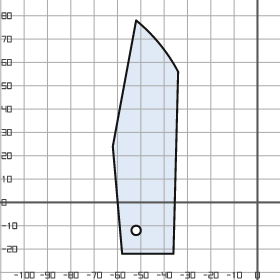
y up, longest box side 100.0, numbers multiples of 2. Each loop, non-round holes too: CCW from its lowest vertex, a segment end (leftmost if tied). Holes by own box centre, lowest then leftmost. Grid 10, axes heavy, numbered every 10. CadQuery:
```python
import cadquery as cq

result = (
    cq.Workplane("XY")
    .moveTo(-58.0, -22.0)
    .lineTo(-36.0, -22.0)
    .lineTo(-34.0, 56.0)
    .threePointArc((-42.0, 68.0), (-52.0, 78.0))
    .lineTo(-62.0, 24.0)
    .close()
    .moveTo(-52.0, -12.0)
    .circle(2.0)
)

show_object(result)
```